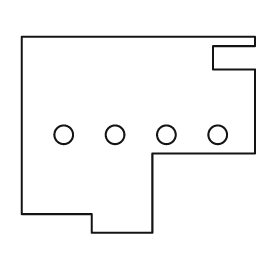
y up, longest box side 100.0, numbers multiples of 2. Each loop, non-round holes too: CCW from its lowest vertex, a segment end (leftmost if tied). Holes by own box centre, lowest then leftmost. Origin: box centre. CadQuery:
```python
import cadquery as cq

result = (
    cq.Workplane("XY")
    .moveTo(-20.0, -42.0)
    .lineTo(6.0, -42.0)
    .lineTo(6.0, -8.0)
    .lineTo(50.0, -8.0)
    .lineTo(50.0, 28.0)
    .lineTo(32.0, 28.0)
    .lineTo(32.0, 38.0)
    .lineTo(50.0, 38.0)
    .lineTo(50.0, 42.0)
    .lineTo(-50.0, 42.0)
    .lineTo(-50.0, -34.0)
    .lineTo(-20.0, -34.0)
    .close()
    .moveTo(-32.0, 0.0)
    .circle(4.0)
    .moveTo(-10.0, 0.0)
    .circle(4.0)
    .moveTo(12.0, 0.0)
    .circle(4.0)
    .moveTo(34.0, 0.0)
    .circle(4.0)
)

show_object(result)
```